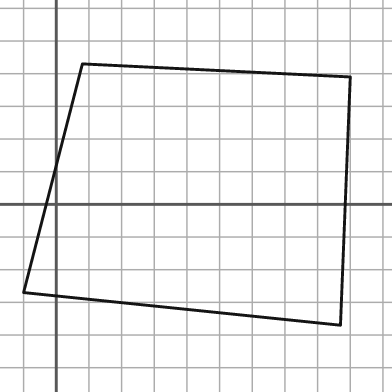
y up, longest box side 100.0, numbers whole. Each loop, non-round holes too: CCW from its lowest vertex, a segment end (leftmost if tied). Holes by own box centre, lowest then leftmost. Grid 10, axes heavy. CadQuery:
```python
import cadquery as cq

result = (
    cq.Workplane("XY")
    .moveTo(87.0, -37.0)
    .lineTo(90.0, 39.0)
    .lineTo(8.0, 43.0)
    .lineTo(-10.0, -27.0)
    .close()
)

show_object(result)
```